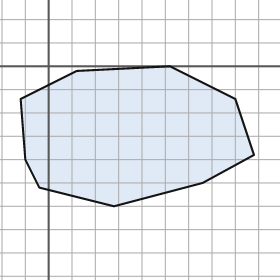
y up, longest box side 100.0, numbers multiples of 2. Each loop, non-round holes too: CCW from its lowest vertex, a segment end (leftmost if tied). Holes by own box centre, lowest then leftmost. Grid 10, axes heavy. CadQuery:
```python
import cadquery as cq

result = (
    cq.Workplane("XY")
    .moveTo(28.0, -60.0)
    .lineTo(66.0, -50.0)
    .lineTo(88.0, -38.0)
    .lineTo(80.0, -14.0)
    .lineTo(52.0, 0.0)
    .lineTo(12.0, -2.0)
    .lineTo(-12.0, -14.0)
    .lineTo(-10.0, -40.0)
    .lineTo(-4.0, -52.0)
    .close()
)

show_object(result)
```